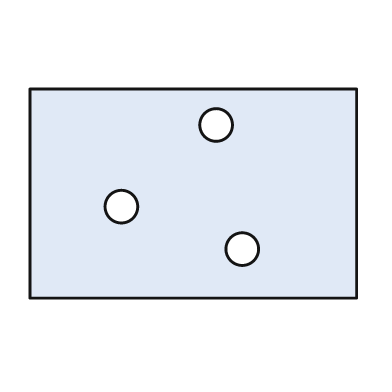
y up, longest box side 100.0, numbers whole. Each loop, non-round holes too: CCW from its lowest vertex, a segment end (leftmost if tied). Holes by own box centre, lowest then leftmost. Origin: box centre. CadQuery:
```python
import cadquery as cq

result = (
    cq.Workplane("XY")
    .moveTo(-50.0, -32.0)
    .lineTo(50.0, -32.0)
    .lineTo(50.0, 32.0)
    .lineTo(-50.0, 32.0)
    .close()
    .moveTo(15.0, -17.0)
    .circle(5.0)
    .moveTo(-22.0, -4.0)
    .circle(5.0)
    .moveTo(7.0, 21.0)
    .circle(5.0)
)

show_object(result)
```